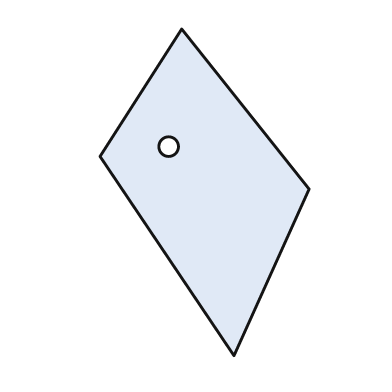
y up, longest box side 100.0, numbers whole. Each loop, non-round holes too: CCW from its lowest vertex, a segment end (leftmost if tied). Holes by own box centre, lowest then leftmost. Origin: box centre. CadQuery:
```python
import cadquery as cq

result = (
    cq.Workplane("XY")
    .moveTo(9.0, -50.0)
    .lineTo(32.0, 1.0)
    .lineTo(-7.0, 50.0)
    .lineTo(-32.0, 11.0)
    .close()
    .moveTo(-11.0, 14.0)
    .circle(3.0)
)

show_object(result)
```